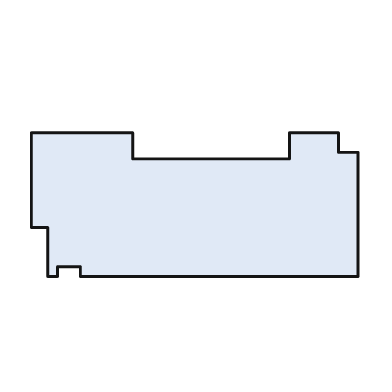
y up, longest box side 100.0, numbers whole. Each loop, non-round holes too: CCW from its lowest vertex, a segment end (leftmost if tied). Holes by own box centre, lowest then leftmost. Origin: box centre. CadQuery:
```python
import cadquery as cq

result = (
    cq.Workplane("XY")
    .moveTo(-45.0, -22.0)
    .lineTo(-42.0, -22.0)
    .lineTo(-42.0, -19.0)
    .lineTo(-35.0, -19.0)
    .lineTo(-35.0, -22.0)
    .lineTo(50.0, -22.0)
    .lineTo(50.0, 16.0)
    .lineTo(44.0, 16.0)
    .lineTo(44.0, 22.0)
    .lineTo(29.0, 22.0)
    .lineTo(29.0, 14.0)
    .lineTo(-19.0, 14.0)
    .lineTo(-19.0, 22.0)
    .lineTo(-50.0, 22.0)
    .lineTo(-50.0, -7.0)
    .lineTo(-45.0, -7.0)
    .close()
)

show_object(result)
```